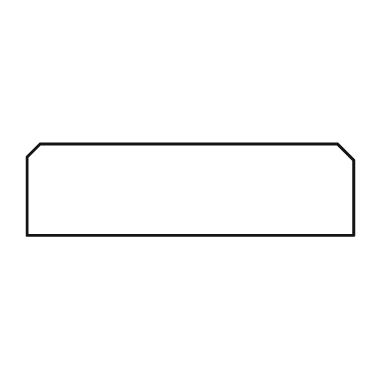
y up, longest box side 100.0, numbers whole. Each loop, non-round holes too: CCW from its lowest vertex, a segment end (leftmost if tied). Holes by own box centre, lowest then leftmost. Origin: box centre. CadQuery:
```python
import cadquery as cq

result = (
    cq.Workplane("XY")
    .moveTo(-50.0, -14.0)
    .lineTo(50.0, -14.0)
    .lineTo(50.0, 9.0)
    .lineTo(45.0, 14.0)
    .lineTo(-46.0, 14.0)
    .lineTo(-50.0, 10.0)
    .close()
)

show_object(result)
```